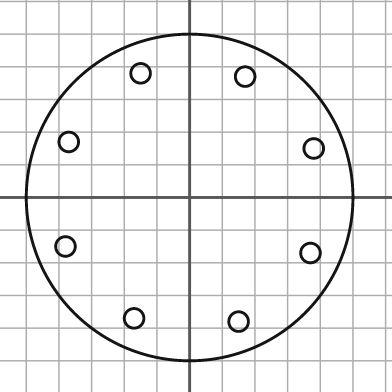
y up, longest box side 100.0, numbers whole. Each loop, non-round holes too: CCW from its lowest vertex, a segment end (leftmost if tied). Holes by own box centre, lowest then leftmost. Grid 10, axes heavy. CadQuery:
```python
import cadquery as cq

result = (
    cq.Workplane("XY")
    .moveTo(0.0, 0.0)
    .circle(50.0)
    .moveTo(15.0, -38.0)
    .circle(3.0)
    .moveTo(-17.0, -37.0)
    .circle(3.0)
    .moveTo(37.0, -17.0)
    .circle(3.0)
    .moveTo(-38.0, -15.0)
    .circle(3.0)
    .moveTo(38.0, 15.0)
    .circle(3.0)
    .moveTo(-37.0, 17.0)
    .circle(3.0)
    .moveTo(17.0, 37.0)
    .circle(3.0)
    .moveTo(-15.0, 38.0)
    .circle(3.0)
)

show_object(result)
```